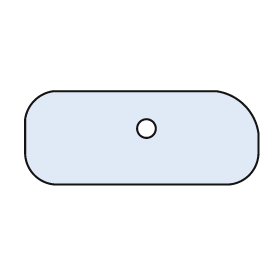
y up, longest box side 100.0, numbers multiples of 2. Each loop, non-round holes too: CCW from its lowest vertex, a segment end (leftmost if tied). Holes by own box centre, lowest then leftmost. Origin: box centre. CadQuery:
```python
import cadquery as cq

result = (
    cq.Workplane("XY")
    .moveTo(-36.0, -20.0)
    .lineTo(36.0, -20.0)
    .threePointArc((46.0, -16.0), (50.0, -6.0))
    .lineTo(50.0, 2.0)
    .threePointArc((44.0, 14.0), (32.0, 20.0))
    .lineTo(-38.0, 20.0)
    .threePointArc((-46.0, 16.0), (-50.0, 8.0))
    .lineTo(-50.0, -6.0)
    .threePointArc((-46.0, -16.0), (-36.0, -20.0))
    .close()
    .moveTo(2.0, 4.0)
    .circle(4.0)
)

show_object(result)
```